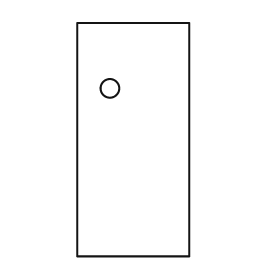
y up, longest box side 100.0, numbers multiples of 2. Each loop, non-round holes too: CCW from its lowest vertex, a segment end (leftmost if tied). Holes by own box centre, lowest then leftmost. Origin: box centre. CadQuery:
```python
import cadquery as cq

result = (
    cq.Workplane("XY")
    .moveTo(-24.0, -50.0)
    .lineTo(24.0, -50.0)
    .lineTo(24.0, 50.0)
    .lineTo(-24.0, 50.0)
    .close()
    .moveTo(-10.0, 22.0)
    .circle(4.0)
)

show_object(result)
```